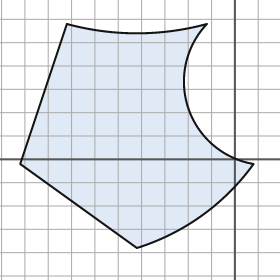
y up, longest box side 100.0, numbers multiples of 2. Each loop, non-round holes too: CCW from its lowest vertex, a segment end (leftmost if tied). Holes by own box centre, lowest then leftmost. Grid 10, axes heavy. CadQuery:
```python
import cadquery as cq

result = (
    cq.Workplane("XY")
    .moveTo(-42.0, -38.0)
    .threePointArc((-14.0, -24.0), (8.0, -2.0))
    .threePointArc((-20.0, 22.0), (-12.0, 58.0))
    .threePointArc((-42.0, 54.0), (-72.0, 58.0))
    .lineTo(-92.0, -2.0)
    .close()
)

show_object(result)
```